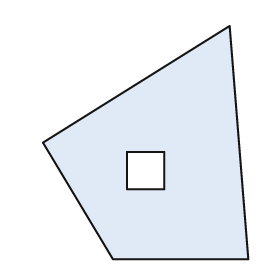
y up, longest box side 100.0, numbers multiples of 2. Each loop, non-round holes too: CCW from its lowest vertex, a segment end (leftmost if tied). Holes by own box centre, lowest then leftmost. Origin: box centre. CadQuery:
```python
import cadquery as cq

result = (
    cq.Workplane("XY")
    .moveTo(-14.0, -50.0)
    .lineTo(44.0, -50.0)
    .lineTo(36.0, 50.0)
    .lineTo(-44.0, 0.0)
    .close()
    .moveTo(-8.0, -20.0)
    .lineTo(8.0, -20.0)
    .lineTo(8.0, -4.0)
    .lineTo(-8.0, -4.0)
    .close()
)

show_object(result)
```